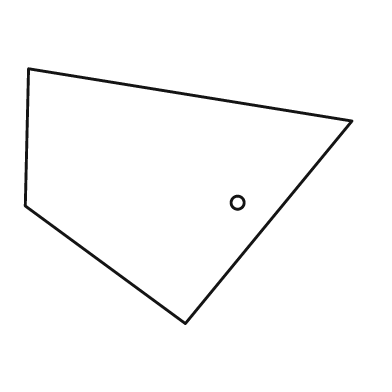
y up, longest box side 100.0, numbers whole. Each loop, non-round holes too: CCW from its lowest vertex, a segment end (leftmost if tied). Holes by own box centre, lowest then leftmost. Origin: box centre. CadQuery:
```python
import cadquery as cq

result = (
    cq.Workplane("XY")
    .moveTo(-1.0, -39.0)
    .lineTo(50.0, 23.0)
    .lineTo(-49.0, 39.0)
    .lineTo(-50.0, -3.0)
    .close()
    .moveTo(15.0, -2.0)
    .circle(2.0)
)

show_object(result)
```